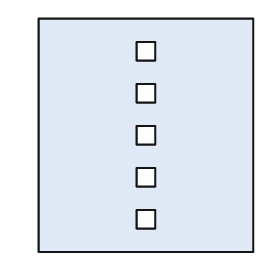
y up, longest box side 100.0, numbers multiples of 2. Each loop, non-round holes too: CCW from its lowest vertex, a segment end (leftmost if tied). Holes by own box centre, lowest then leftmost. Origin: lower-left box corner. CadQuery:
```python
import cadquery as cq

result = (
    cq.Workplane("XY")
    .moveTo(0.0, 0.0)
    .lineTo(92.0, 0.0)
    .lineTo(92.0, 100.0)
    .lineTo(0.0, 100.0)
    .close()
    .moveTo(42.0, 10.0)
    .lineTo(50.0, 10.0)
    .lineTo(50.0, 18.0)
    .lineTo(42.0, 18.0)
    .close()
    .moveTo(42.0, 28.0)
    .lineTo(50.0, 28.0)
    .lineTo(50.0, 36.0)
    .lineTo(42.0, 36.0)
    .close()
    .moveTo(42.0, 46.0)
    .lineTo(50.0, 46.0)
    .lineTo(50.0, 54.0)
    .lineTo(42.0, 54.0)
    .close()
    .moveTo(42.0, 64.0)
    .lineTo(50.0, 64.0)
    .lineTo(50.0, 72.0)
    .lineTo(42.0, 72.0)
    .close()
    .moveTo(42.0, 82.0)
    .lineTo(50.0, 82.0)
    .lineTo(50.0, 90.0)
    .lineTo(42.0, 90.0)
    .close()
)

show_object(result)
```